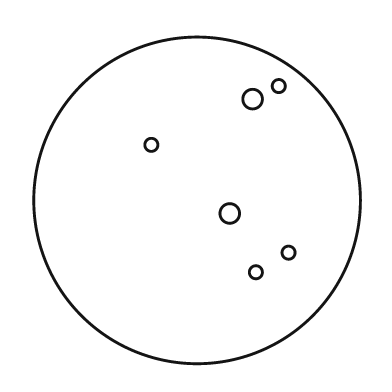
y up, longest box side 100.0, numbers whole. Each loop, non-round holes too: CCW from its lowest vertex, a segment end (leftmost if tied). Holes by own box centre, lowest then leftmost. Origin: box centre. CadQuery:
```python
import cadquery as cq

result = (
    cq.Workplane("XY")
    .moveTo(0.0, 0.0)
    .circle(50.0)
    .moveTo(18.0, -22.0)
    .circle(2.0)
    .moveTo(28.0, -16.0)
    .circle(2.0)
    .moveTo(10.0, -4.0)
    .circle(3.0)
    .moveTo(-14.0, 17.0)
    .circle(2.0)
    .moveTo(17.0, 31.0)
    .circle(3.0)
    .moveTo(25.0, 35.0)
    .circle(2.0)
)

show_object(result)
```